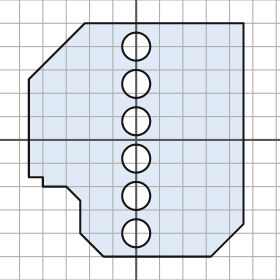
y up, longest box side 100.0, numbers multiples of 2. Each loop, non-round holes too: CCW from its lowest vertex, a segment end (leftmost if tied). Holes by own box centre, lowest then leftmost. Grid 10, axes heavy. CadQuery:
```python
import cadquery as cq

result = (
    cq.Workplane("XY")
    .moveTo(-14.0, -50.0)
    .lineTo(32.0, -50.0)
    .lineTo(46.0, -36.0)
    .lineTo(46.0, 50.0)
    .lineTo(-22.0, 50.0)
    .lineTo(-46.0, 26.0)
    .lineTo(-46.0, -16.0)
    .lineTo(-40.0, -16.0)
    .lineTo(-40.0, -20.0)
    .lineTo(-30.0, -20.0)
    .lineTo(-24.0, -26.0)
    .lineTo(-24.0, -40.0)
    .close()
    .moveTo(0.0, -40.0)
    .circle(6.0)
    .moveTo(0.0, -24.0)
    .circle(6.0)
    .moveTo(0.0, -8.0)
    .circle(6.0)
    .moveTo(0.0, 8.0)
    .circle(6.0)
    .moveTo(0.0, 24.0)
    .circle(6.0)
    .moveTo(0.0, 40.0)
    .circle(6.0)
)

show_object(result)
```